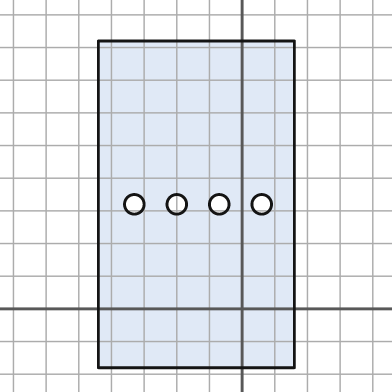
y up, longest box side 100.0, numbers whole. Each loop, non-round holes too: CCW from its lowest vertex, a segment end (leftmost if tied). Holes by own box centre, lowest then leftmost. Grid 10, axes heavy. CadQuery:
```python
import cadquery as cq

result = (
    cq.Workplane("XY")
    .moveTo(-44.0, -18.0)
    .lineTo(16.0, -18.0)
    .lineTo(16.0, 82.0)
    .lineTo(-44.0, 82.0)
    .close()
    .moveTo(-33.0, 32.0)
    .circle(3.0)
    .moveTo(-20.0, 32.0)
    .circle(3.0)
    .moveTo(-7.0, 32.0)
    .circle(3.0)
    .moveTo(6.0, 32.0)
    .circle(3.0)
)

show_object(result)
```